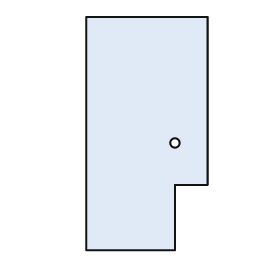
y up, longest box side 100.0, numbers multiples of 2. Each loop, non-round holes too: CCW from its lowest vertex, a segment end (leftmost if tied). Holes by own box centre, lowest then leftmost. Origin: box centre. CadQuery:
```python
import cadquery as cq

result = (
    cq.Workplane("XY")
    .moveTo(-26.0, -50.0)
    .lineTo(12.0, -50.0)
    .lineTo(12.0, -22.0)
    .lineTo(26.0, -22.0)
    .lineTo(26.0, 50.0)
    .lineTo(-26.0, 50.0)
    .close()
    .moveTo(12.0, -4.0)
    .circle(2.0)
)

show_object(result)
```